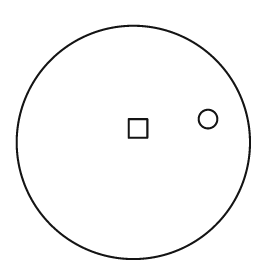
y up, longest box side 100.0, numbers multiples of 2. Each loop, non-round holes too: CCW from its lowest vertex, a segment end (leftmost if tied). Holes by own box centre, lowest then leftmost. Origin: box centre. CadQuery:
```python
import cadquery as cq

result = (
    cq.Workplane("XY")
    .moveTo(0.0, 0.0)
    .circle(50.0)
    .moveTo(-2.0, 2.0)
    .lineTo(6.0, 2.0)
    .lineTo(6.0, 10.0)
    .lineTo(-2.0, 10.0)
    .close()
    .moveTo(32.0, 10.0)
    .circle(4.0)
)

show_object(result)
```